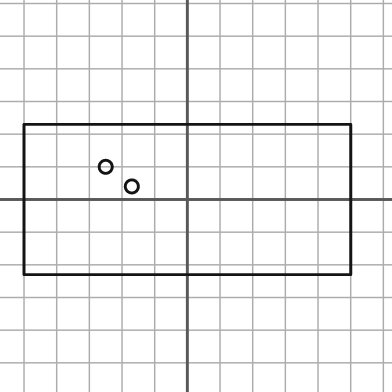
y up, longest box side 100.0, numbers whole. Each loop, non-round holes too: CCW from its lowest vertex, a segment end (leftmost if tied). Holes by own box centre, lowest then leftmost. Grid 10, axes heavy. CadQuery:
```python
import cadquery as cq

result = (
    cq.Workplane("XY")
    .moveTo(-50.0, -23.0)
    .lineTo(50.0, -23.0)
    .lineTo(50.0, 23.0)
    .lineTo(-50.0, 23.0)
    .close()
    .moveTo(-17.0, 4.0)
    .circle(2.0)
    .moveTo(-25.0, 10.0)
    .circle(2.0)
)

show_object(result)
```